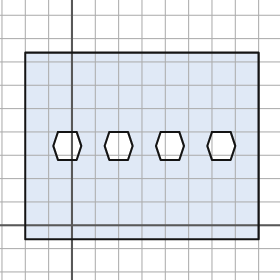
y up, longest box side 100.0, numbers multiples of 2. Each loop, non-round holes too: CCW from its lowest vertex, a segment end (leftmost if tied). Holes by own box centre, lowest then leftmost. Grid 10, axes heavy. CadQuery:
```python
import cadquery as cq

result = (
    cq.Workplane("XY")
    .moveTo(-20.0, -6.0)
    .lineTo(80.0, -6.0)
    .lineTo(80.0, 74.0)
    .lineTo(-20.0, 74.0)
    .close()
    .moveTo(-6.0, 28.0)
    .lineTo(2.0, 28.0)
    .lineTo(4.0, 34.0)
    .lineTo(2.0, 40.0)
    .lineTo(-6.0, 40.0)
    .lineTo(-8.0, 34.0)
    .close()
    .moveTo(16.0, 28.0)
    .lineTo(24.0, 28.0)
    .lineTo(26.0, 34.0)
    .lineTo(24.0, 40.0)
    .lineTo(16.0, 40.0)
    .lineTo(14.0, 34.0)
    .close()
    .moveTo(38.0, 28.0)
    .lineTo(46.0, 28.0)
    .lineTo(48.0, 34.0)
    .lineTo(46.0, 40.0)
    .lineTo(38.0, 40.0)
    .lineTo(36.0, 34.0)
    .close()
    .moveTo(60.0, 28.0)
    .lineTo(68.0, 28.0)
    .lineTo(70.0, 34.0)
    .lineTo(68.0, 40.0)
    .lineTo(60.0, 40.0)
    .lineTo(58.0, 34.0)
    .close()
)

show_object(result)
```